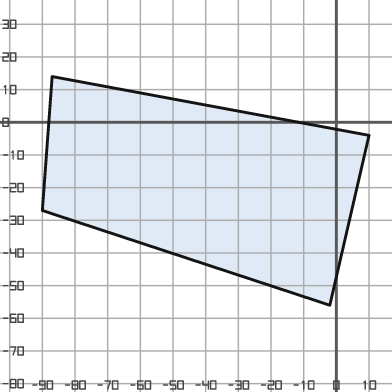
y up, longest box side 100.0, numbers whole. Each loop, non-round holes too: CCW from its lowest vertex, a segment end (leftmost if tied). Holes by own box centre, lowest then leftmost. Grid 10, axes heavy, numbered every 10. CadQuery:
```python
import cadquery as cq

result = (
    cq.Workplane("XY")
    .moveTo(-2.0, -56.0)
    .lineTo(10.0, -4.0)
    .lineTo(-87.0, 14.0)
    .lineTo(-90.0, -27.0)
    .close()
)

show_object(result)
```